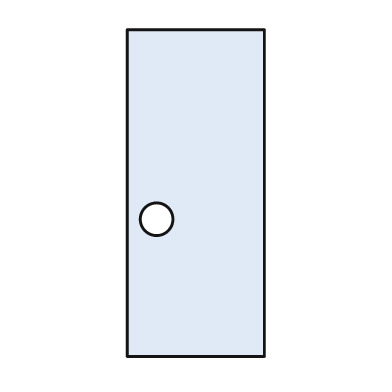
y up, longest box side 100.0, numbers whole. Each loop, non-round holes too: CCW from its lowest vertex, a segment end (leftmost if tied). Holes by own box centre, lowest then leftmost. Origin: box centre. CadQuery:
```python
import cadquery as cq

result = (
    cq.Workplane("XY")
    .moveTo(-21.0, -50.0)
    .lineTo(21.0, -50.0)
    .lineTo(21.0, 50.0)
    .lineTo(-21.0, 50.0)
    .close()
    .moveTo(-12.0, -8.0)
    .circle(5.0)
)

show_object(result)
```